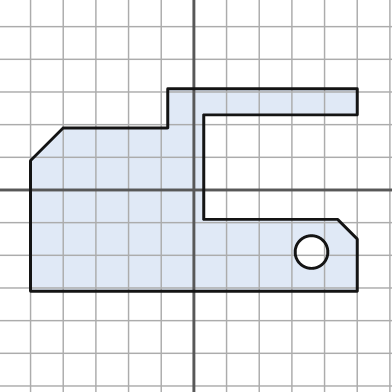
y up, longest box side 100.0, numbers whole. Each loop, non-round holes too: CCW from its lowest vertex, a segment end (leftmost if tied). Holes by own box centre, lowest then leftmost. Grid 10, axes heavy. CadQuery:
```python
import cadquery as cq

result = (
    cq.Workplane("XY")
    .moveTo(-50.0, -31.0)
    .lineTo(50.0, -31.0)
    .lineTo(50.0, -15.0)
    .lineTo(44.0, -9.0)
    .lineTo(3.0, -9.0)
    .lineTo(3.0, 23.0)
    .lineTo(50.0, 23.0)
    .lineTo(50.0, 31.0)
    .lineTo(-8.0, 31.0)
    .lineTo(-8.0, 19.0)
    .lineTo(-40.0, 19.0)
    .lineTo(-50.0, 9.0)
    .close()
    .moveTo(36.0, -19.0)
    .circle(5.0)
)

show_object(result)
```